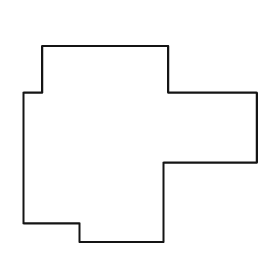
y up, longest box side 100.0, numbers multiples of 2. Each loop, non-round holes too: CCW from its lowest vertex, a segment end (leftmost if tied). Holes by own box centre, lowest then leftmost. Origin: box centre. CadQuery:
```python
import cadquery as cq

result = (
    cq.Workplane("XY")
    .moveTo(-26.0, -42.0)
    .lineTo(10.0, -42.0)
    .lineTo(10.0, -8.0)
    .lineTo(50.0, -8.0)
    .lineTo(50.0, 22.0)
    .lineTo(12.0, 22.0)
    .lineTo(12.0, 42.0)
    .lineTo(-42.0, 42.0)
    .lineTo(-42.0, 22.0)
    .lineTo(-50.0, 22.0)
    .lineTo(-50.0, -34.0)
    .lineTo(-26.0, -34.0)
    .close()
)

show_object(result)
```